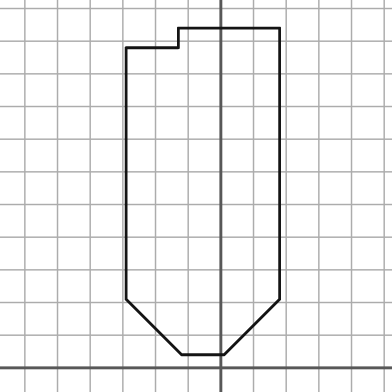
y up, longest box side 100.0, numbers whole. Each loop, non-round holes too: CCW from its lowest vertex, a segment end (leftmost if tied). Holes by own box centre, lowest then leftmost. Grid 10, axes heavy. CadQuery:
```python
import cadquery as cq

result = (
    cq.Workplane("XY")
    .moveTo(-12.0, 4.0)
    .lineTo(1.0, 4.0)
    .lineTo(18.0, 21.0)
    .lineTo(18.0, 104.0)
    .lineTo(-13.0, 104.0)
    .lineTo(-13.0, 98.0)
    .lineTo(-29.0, 98.0)
    .lineTo(-29.0, 21.0)
    .close()
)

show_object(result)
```